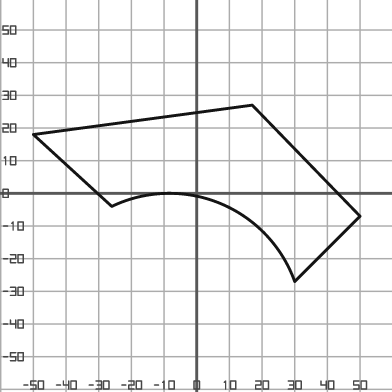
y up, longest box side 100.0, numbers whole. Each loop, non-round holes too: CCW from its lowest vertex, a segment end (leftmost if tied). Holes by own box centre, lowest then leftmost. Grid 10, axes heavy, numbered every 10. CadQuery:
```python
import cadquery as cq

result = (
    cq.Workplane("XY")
    .moveTo(30.0, -27.0)
    .lineTo(50.0, -7.0)
    .lineTo(17.0, 27.0)
    .lineTo(-50.0, 18.0)
    .lineTo(-26.0, -4.0)
    .threePointArc((7.0, -3.0), (30.0, -27.0))
    .close()
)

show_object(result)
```